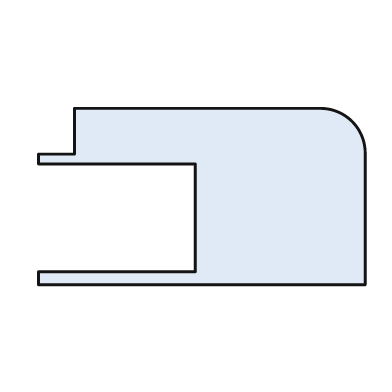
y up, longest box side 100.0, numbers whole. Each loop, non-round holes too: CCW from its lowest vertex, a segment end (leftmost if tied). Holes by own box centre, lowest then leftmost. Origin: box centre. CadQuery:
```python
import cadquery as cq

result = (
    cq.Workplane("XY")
    .moveTo(-50.0, -27.0)
    .lineTo(50.0, -27.0)
    .lineTo(50.0, 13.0)
    .threePointArc((46.0, 23.0), (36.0, 27.0))
    .lineTo(-39.0, 27.0)
    .lineTo(-39.0, 13.0)
    .lineTo(-50.0, 13.0)
    .lineTo(-50.0, 10.0)
    .lineTo(-2.0, 10.0)
    .lineTo(-2.0, -23.0)
    .lineTo(-50.0, -23.0)
    .close()
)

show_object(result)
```